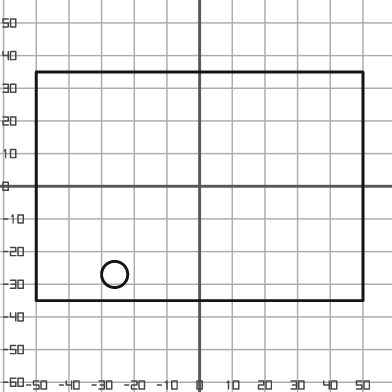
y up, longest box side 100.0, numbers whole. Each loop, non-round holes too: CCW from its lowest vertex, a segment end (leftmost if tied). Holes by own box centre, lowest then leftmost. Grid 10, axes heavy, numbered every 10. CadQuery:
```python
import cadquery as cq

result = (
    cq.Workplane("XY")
    .moveTo(-50.0, -35.0)
    .lineTo(50.0, -35.0)
    .lineTo(50.0, 35.0)
    .lineTo(-50.0, 35.0)
    .close()
    .moveTo(-26.0, -27.0)
    .circle(4.0)
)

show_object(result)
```